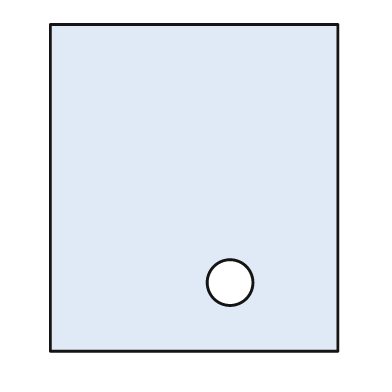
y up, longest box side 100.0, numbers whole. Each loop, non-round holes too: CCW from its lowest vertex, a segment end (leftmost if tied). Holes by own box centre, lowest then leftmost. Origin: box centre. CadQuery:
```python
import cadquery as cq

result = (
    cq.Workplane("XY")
    .moveTo(-44.0, -50.0)
    .lineTo(44.0, -50.0)
    .lineTo(44.0, 50.0)
    .lineTo(-44.0, 50.0)
    .close()
    .moveTo(11.0, -29.0)
    .circle(7.0)
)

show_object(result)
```